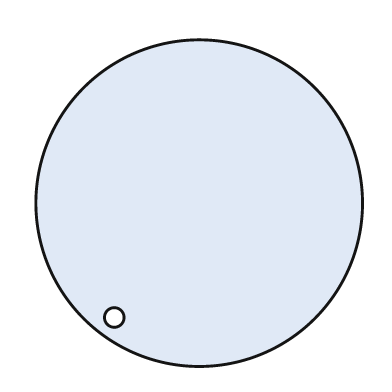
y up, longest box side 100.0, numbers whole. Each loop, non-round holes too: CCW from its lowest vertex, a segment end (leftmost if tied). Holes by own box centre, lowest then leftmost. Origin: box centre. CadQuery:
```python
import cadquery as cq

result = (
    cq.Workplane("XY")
    .moveTo(0.0, 0.0)
    .circle(50.0)
    .moveTo(-26.0, -35.0)
    .circle(3.0)
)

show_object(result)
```